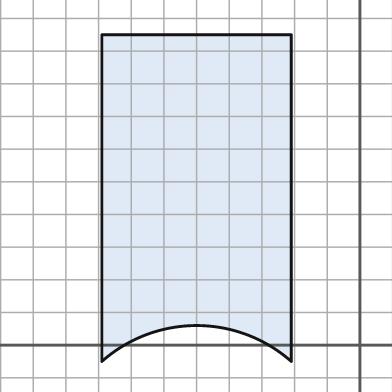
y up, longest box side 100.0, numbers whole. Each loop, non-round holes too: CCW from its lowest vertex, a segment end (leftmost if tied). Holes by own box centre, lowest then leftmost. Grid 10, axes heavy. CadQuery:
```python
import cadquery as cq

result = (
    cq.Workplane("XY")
    .moveTo(-79.0, -5.0)
    .threePointArc((-50.0, 6.0), (-21.0, -5.0))
    .lineTo(-21.0, 95.0)
    .lineTo(-79.0, 95.0)
    .close()
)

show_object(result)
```